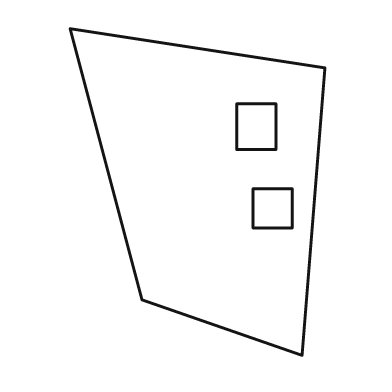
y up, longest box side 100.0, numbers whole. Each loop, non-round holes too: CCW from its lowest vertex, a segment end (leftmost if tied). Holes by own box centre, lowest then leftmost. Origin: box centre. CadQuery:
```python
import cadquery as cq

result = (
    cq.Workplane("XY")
    .moveTo(32.0, -50.0)
    .lineTo(39.0, 38.0)
    .lineTo(-39.0, 50.0)
    .lineTo(-17.0, -33.0)
    .close()
    .moveTo(17.0, -11.0)
    .lineTo(29.0, -11.0)
    .lineTo(29.0, 1.0)
    .lineTo(17.0, 1.0)
    .close()
    .moveTo(12.0, 13.0)
    .lineTo(24.0, 13.0)
    .lineTo(24.0, 27.0)
    .lineTo(12.0, 27.0)
    .close()
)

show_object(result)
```